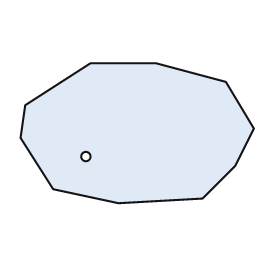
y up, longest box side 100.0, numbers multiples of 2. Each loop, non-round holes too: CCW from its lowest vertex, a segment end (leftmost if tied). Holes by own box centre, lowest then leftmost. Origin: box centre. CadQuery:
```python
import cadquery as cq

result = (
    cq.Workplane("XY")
    .moveTo(-8.0, -30.0)
    .lineTo(28.0, -28.0)
    .lineTo(42.0, -14.0)
    .lineTo(50.0, 2.0)
    .lineTo(38.0, 22.0)
    .lineTo(8.0, 30.0)
    .lineTo(-20.0, 30.0)
    .lineTo(-48.0, 12.0)
    .lineTo(-50.0, -2.0)
    .lineTo(-36.0, -24.0)
    .close()
    .moveTo(-22.0, -10.0)
    .circle(2.0)
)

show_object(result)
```